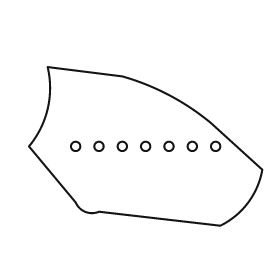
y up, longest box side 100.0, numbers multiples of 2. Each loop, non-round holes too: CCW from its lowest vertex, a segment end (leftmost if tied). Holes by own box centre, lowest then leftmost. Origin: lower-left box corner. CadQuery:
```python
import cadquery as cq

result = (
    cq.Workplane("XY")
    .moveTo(82.0, 0.0)
    .threePointArc((94.0, 10.0), (100.0, 24.0))
    .lineTo(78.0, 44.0)
    .threePointArc((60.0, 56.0), (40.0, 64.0))
    .lineTo(8.0, 68.0)
    .threePointArc((8.0, 50.0), (0.0, 34.0))
    .lineTo(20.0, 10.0)
    .threePointArc((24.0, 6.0), (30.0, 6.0))
    .close()
    .moveTo(20.0, 34.0)
    .circle(2.0)
    .moveTo(30.0, 34.0)
    .circle(2.0)
    .moveTo(40.0, 34.0)
    .circle(2.0)
    .moveTo(50.0, 34.0)
    .circle(2.0)
    .moveTo(60.0, 34.0)
    .circle(2.0)
    .moveTo(70.0, 34.0)
    .circle(2.0)
    .moveTo(80.0, 34.0)
    .circle(2.0)
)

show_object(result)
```